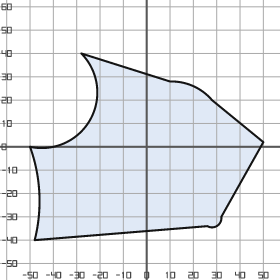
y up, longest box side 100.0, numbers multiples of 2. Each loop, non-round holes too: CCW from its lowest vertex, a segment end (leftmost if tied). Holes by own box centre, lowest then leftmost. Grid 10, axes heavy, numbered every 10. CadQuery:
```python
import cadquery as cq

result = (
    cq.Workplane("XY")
    .moveTo(-48.0, -40.0)
    .lineTo(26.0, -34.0)
    .threePointArc((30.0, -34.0), (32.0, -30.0))
    .lineTo(50.0, 2.0)
    .lineTo(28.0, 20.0)
    .threePointArc((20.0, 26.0), (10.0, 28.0))
    .lineTo(-28.0, 40.0)
    .threePointArc((-24.0, 12.0), (-50.0, 0.0))
    .threePointArc((-46.0, -20.0), (-48.0, -40.0))
    .close()
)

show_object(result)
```